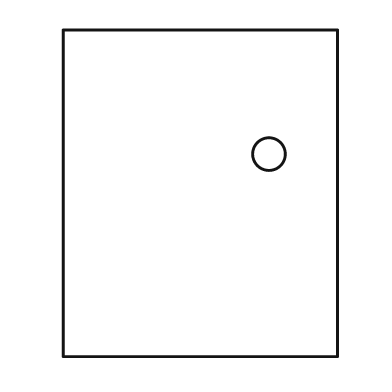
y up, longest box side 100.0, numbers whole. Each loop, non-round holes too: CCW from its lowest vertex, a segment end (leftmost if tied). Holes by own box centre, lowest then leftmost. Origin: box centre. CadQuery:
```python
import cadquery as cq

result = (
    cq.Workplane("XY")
    .moveTo(-42.0, -50.0)
    .lineTo(42.0, -50.0)
    .lineTo(42.0, 50.0)
    .lineTo(-42.0, 50.0)
    .close()
    .moveTo(21.0, 12.0)
    .circle(5.0)
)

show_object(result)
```